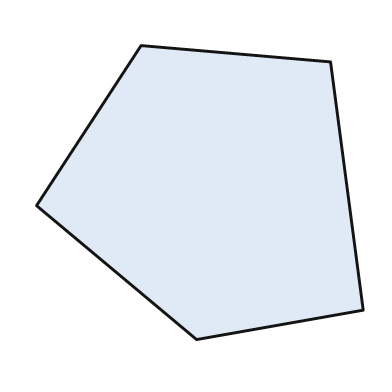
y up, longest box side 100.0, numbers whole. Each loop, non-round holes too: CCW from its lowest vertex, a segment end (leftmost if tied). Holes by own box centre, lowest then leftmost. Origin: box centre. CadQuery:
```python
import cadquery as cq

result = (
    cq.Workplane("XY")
    .moveTo(-1.0, -45.0)
    .lineTo(50.0, -36.0)
    .lineTo(40.0, 40.0)
    .lineTo(-18.0, 45.0)
    .lineTo(-50.0, -4.0)
    .close()
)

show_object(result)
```